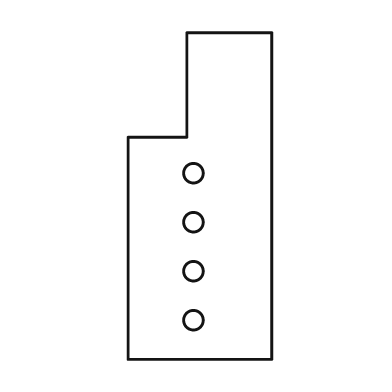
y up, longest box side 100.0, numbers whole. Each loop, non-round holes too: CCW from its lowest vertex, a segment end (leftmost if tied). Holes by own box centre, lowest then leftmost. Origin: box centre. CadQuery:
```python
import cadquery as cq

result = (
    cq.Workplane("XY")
    .moveTo(-22.0, -50.0)
    .lineTo(22.0, -50.0)
    .lineTo(22.0, 50.0)
    .lineTo(-4.0, 50.0)
    .lineTo(-4.0, 18.0)
    .lineTo(-22.0, 18.0)
    .close()
    .moveTo(-2.0, -38.0)
    .circle(3.0)
    .moveTo(-2.0, -23.0)
    .circle(3.0)
    .moveTo(-2.0, -8.0)
    .circle(3.0)
    .moveTo(-2.0, 7.0)
    .circle(3.0)
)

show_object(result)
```